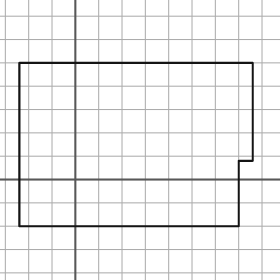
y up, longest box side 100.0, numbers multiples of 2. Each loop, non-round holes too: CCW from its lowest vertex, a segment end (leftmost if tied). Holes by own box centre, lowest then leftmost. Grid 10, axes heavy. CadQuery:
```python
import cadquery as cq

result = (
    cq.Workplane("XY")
    .moveTo(-24.0, -20.0)
    .lineTo(70.0, -20.0)
    .lineTo(70.0, 8.0)
    .lineTo(76.0, 8.0)
    .lineTo(76.0, 50.0)
    .lineTo(-24.0, 50.0)
    .close()
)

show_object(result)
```